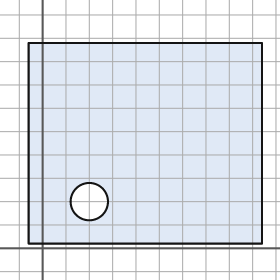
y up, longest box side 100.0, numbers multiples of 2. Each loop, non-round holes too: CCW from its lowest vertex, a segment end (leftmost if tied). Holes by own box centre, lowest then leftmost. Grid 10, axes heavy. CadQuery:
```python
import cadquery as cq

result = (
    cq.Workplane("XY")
    .moveTo(-6.0, 2.0)
    .lineTo(94.0, 2.0)
    .lineTo(94.0, 88.0)
    .lineTo(-6.0, 88.0)
    .close()
    .moveTo(20.0, 20.0)
    .circle(8.0)
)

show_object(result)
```